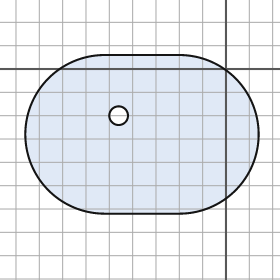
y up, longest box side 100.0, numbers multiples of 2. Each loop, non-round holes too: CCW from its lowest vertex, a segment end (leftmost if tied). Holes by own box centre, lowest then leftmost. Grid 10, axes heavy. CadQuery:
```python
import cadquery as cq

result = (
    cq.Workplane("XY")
    .moveTo(-52.0, -62.0)
    .lineTo(-20.0, -62.0)
    .threePointArc((14.0, -28.0), (-20.0, 6.0))
    .lineTo(-52.0, 6.0)
    .threePointArc((-86.0, -28.0), (-52.0, -62.0))
    .close()
    .moveTo(-46.0, -20.0)
    .circle(4.0)
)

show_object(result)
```